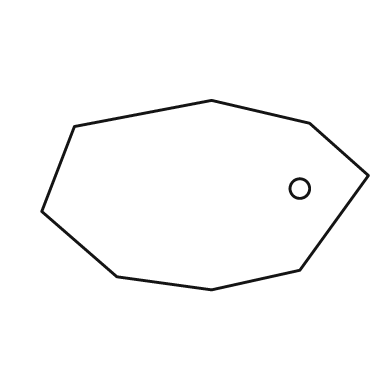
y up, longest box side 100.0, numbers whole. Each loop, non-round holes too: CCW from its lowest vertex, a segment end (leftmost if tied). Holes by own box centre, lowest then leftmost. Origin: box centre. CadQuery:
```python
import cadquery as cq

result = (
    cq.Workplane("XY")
    .moveTo(2.0, -29.0)
    .lineTo(29.0, -23.0)
    .lineTo(50.0, 6.0)
    .lineTo(32.0, 22.0)
    .lineTo(2.0, 29.0)
    .lineTo(-40.0, 21.0)
    .lineTo(-50.0, -5.0)
    .lineTo(-27.0, -25.0)
    .close()
    .moveTo(29.0, 2.0)
    .circle(3.0)
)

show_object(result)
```